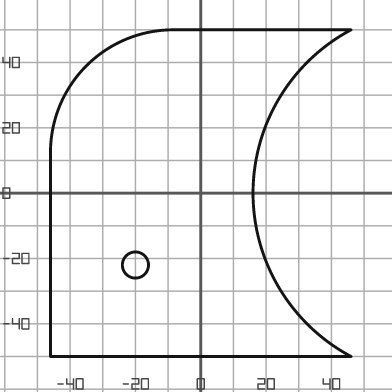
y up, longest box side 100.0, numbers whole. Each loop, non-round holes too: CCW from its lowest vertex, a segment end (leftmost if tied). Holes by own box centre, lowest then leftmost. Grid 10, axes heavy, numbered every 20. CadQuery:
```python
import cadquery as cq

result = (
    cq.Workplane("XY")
    .moveTo(-46.0, -50.0)
    .lineTo(46.0, -50.0)
    .threePointArc((16.0, 0.0), (46.0, 50.0))
    .lineTo(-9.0, 50.0)
    .threePointArc((-35.0, 39.0), (-46.0, 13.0))
    .close()
    .moveTo(-20.0, -22.0)
    .circle(4.0)
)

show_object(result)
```